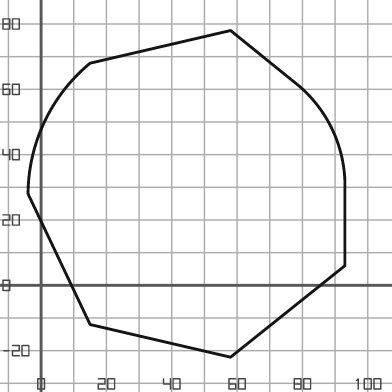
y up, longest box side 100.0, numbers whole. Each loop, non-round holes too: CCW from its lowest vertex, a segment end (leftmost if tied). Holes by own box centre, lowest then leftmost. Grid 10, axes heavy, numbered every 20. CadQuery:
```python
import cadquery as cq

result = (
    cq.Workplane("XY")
    .moveTo(58.0, -22.0)
    .lineTo(93.0, 6.0)
    .lineTo(93.0, 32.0)
    .threePointArc((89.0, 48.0), (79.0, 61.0))
    .lineTo(58.0, 78.0)
    .lineTo(15.0, 68.0)
    .threePointArc((1.0, 50.0), (-4.0, 28.0))
    .lineTo(15.0, -12.0)
    .close()
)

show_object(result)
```